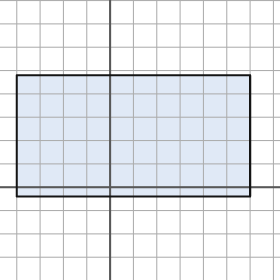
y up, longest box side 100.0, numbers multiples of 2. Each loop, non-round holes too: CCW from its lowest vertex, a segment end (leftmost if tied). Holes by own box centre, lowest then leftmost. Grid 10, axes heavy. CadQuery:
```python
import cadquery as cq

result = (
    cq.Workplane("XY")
    .moveTo(-40.0, -4.0)
    .lineTo(60.0, -4.0)
    .lineTo(60.0, 48.0)
    .lineTo(-40.0, 48.0)
    .close()
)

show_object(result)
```